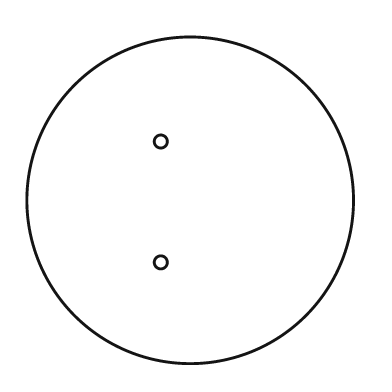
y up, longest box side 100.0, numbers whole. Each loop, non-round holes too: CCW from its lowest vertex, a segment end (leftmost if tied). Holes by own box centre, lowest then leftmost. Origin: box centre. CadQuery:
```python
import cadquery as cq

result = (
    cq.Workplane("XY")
    .moveTo(0.0, 0.0)
    .circle(50.0)
    .moveTo(-9.0, -19.0)
    .circle(2.0)
    .moveTo(-9.0, 18.0)
    .circle(2.0)
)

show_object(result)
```